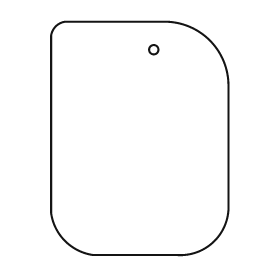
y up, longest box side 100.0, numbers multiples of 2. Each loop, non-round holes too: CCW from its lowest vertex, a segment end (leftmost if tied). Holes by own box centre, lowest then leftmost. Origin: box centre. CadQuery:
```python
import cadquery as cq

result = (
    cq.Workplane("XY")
    .moveTo(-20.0, -50.0)
    .lineTo(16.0, -50.0)
    .threePointArc((32.0, -44.0), (38.0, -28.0))
    .lineTo(38.0, 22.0)
    .threePointArc((30.0, 42.0), (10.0, 50.0))
    .lineTo(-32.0, 50.0)
    .threePointArc((-36.0, 48.0), (-38.0, 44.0))
    .lineTo(-38.0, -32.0)
    .threePointArc((-32.0, -44.0), (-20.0, -50.0))
    .close()
    .moveTo(6.0, 38.0)
    .circle(2.0)
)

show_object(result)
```